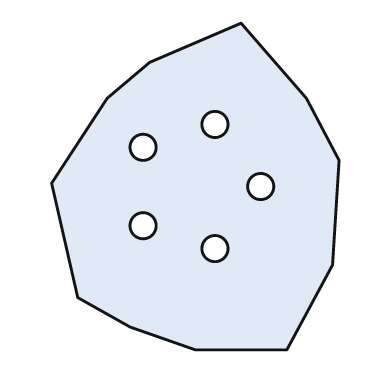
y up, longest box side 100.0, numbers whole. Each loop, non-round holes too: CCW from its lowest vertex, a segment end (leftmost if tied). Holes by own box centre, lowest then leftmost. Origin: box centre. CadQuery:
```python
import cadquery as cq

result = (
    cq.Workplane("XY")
    .moveTo(0.0, -50.0)
    .lineTo(28.0, -50.0)
    .lineTo(42.0, -24.0)
    .lineTo(44.0, 8.0)
    .lineTo(34.0, 27.0)
    .lineTo(14.0, 50.0)
    .lineTo(-14.0, 38.0)
    .lineTo(-27.0, 27.0)
    .lineTo(-44.0, 1.0)
    .lineTo(-36.0, -34.0)
    .lineTo(-20.0, -43.0)
    .close()
    .moveTo(6.0, -19.0)
    .circle(4.0)
    .moveTo(-16.0, -12.0)
    .circle(4.0)
    .moveTo(20.0, 0.0)
    .circle(4.0)
    .moveTo(-16.0, 12.0)
    .circle(4.0)
    .moveTo(6.0, 19.0)
    .circle(4.0)
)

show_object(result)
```